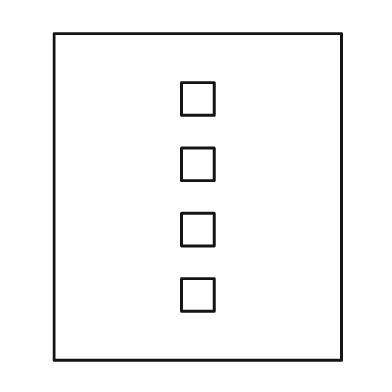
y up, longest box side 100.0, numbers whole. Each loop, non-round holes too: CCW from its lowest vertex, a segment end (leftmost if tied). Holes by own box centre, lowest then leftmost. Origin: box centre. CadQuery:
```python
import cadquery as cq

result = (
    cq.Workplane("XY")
    .moveTo(-44.0, -50.0)
    .lineTo(44.0, -50.0)
    .lineTo(44.0, 50.0)
    .lineTo(-44.0, 50.0)
    .close()
    .moveTo(-5.0, -35.0)
    .lineTo(5.0, -35.0)
    .lineTo(5.0, -25.0)
    .lineTo(-5.0, -25.0)
    .close()
    .moveTo(-5.0, -15.0)
    .lineTo(5.0, -15.0)
    .lineTo(5.0, -5.0)
    .lineTo(-5.0, -5.0)
    .close()
    .moveTo(-5.0, 5.0)
    .lineTo(5.0, 5.0)
    .lineTo(5.0, 15.0)
    .lineTo(-5.0, 15.0)
    .close()
    .moveTo(-5.0, 25.0)
    .lineTo(5.0, 25.0)
    .lineTo(5.0, 35.0)
    .lineTo(-5.0, 35.0)
    .close()
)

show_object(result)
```